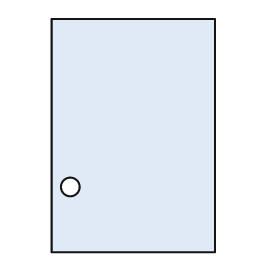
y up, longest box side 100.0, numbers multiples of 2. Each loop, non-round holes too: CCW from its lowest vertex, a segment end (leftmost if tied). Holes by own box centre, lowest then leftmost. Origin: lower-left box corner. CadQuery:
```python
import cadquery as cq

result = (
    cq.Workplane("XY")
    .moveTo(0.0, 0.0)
    .lineTo(70.0, 0.0)
    .lineTo(70.0, 100.0)
    .lineTo(0.0, 100.0)
    .close()
    .moveTo(8.0, 28.0)
    .circle(4.0)
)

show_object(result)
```